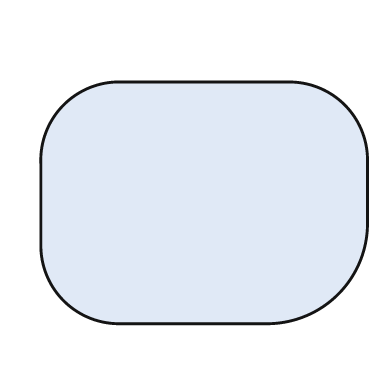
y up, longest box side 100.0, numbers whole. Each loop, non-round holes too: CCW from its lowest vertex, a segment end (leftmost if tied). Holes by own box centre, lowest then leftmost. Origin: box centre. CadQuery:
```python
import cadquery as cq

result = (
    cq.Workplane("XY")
    .moveTo(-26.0, -37.0)
    .lineTo(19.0, -37.0)
    .threePointArc((41.0, -28.0), (50.0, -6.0))
    .lineTo(50.0, 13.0)
    .threePointArc((43.0, 30.0), (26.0, 37.0))
    .lineTo(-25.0, 37.0)
    .threePointArc((-43.0, 30.0), (-50.0, 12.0))
    .lineTo(-50.0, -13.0)
    .threePointArc((-43.0, -30.0), (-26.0, -37.0))
    .close()
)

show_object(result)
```